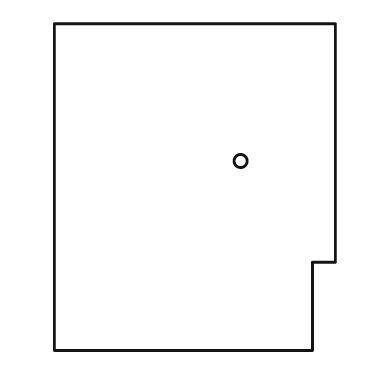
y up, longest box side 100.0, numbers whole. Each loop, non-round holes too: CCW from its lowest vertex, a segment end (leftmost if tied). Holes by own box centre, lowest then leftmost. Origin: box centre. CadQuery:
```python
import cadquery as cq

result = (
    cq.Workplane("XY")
    .moveTo(-43.0, -50.0)
    .lineTo(36.0, -50.0)
    .lineTo(36.0, -23.0)
    .lineTo(43.0, -23.0)
    .lineTo(43.0, 50.0)
    .lineTo(-43.0, 50.0)
    .close()
    .moveTo(14.0, 8.0)
    .circle(2.0)
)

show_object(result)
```